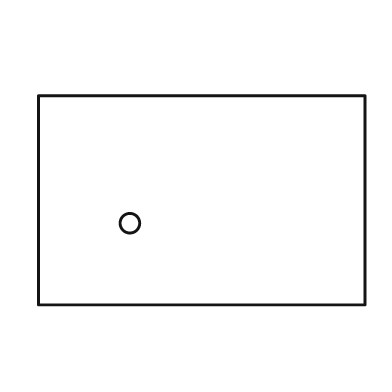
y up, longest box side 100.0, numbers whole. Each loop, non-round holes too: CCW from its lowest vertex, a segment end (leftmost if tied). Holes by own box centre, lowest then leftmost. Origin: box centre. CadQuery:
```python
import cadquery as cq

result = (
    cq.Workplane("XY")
    .moveTo(-50.0, -32.0)
    .lineTo(50.0, -32.0)
    .lineTo(50.0, 32.0)
    .lineTo(-50.0, 32.0)
    .close()
    .moveTo(-22.0, -7.0)
    .circle(3.0)
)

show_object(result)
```